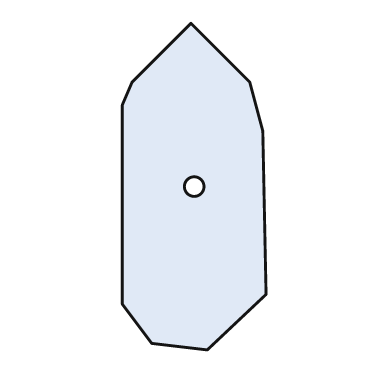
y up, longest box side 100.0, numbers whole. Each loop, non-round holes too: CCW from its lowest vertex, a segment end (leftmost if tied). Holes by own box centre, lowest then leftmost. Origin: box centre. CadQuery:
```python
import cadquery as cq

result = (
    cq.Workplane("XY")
    .moveTo(4.0, -50.0)
    .lineTo(22.0, -33.0)
    .lineTo(21.0, 17.0)
    .lineTo(17.0, 32.0)
    .lineTo(-1.0, 50.0)
    .lineTo(-19.0, 32.0)
    .lineTo(-22.0, 25.0)
    .lineTo(-22.0, -36.0)
    .lineTo(-13.0, -48.0)
    .close()
    .moveTo(0.0, 0.0)
    .circle(3.0)
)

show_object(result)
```